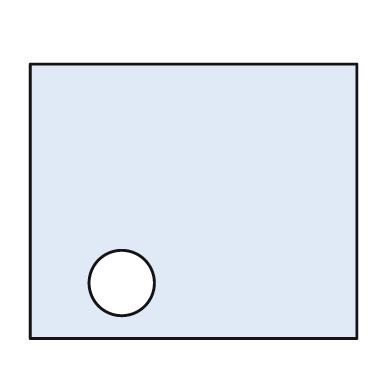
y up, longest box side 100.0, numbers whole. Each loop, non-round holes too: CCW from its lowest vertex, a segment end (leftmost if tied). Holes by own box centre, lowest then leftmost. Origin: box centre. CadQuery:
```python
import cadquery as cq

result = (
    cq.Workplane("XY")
    .moveTo(-50.0, -42.0)
    .lineTo(50.0, -42.0)
    .lineTo(50.0, 42.0)
    .lineTo(-50.0, 42.0)
    .close()
    .moveTo(-22.0, -25.0)
    .circle(10.0)
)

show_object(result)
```